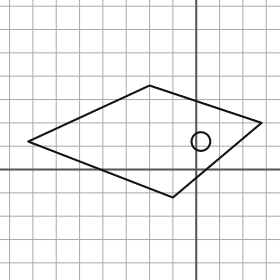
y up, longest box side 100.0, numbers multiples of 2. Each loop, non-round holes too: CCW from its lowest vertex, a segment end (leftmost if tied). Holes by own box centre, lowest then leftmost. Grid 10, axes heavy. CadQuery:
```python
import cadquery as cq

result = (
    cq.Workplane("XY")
    .moveTo(-10.0, -12.0)
    .lineTo(28.0, 20.0)
    .lineTo(-20.0, 36.0)
    .lineTo(-72.0, 12.0)
    .close()
    .moveTo(2.0, 12.0)
    .circle(4.0)
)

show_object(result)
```